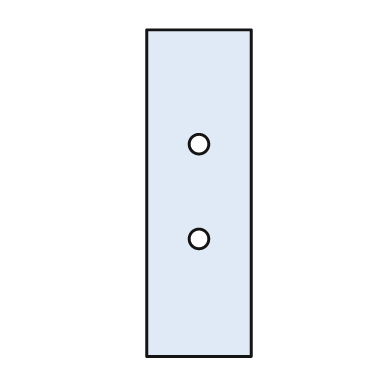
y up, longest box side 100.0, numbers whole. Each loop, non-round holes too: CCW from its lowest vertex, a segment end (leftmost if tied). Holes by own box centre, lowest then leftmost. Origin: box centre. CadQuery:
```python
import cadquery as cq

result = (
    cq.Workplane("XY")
    .moveTo(-16.0, -50.0)
    .lineTo(16.0, -50.0)
    .lineTo(16.0, 50.0)
    .lineTo(-16.0, 50.0)
    .close()
    .moveTo(0.0, -14.0)
    .circle(3.0)
    .moveTo(0.0, 15.0)
    .circle(3.0)
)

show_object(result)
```